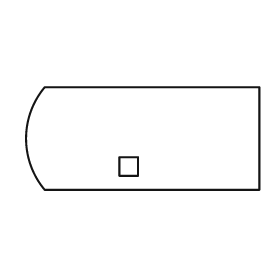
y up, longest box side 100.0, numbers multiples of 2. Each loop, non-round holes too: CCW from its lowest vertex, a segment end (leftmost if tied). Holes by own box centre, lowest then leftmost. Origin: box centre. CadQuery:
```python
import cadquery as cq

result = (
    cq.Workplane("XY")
    .moveTo(-42.0, -22.0)
    .lineTo(50.0, -22.0)
    .lineTo(50.0, 22.0)
    .lineTo(-42.0, 22.0)
    .threePointArc((-50.0, 0.0), (-42.0, -22.0))
    .close()
    .moveTo(-10.0, -16.0)
    .lineTo(-2.0, -16.0)
    .lineTo(-2.0, -8.0)
    .lineTo(-10.0, -8.0)
    .close()
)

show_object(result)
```